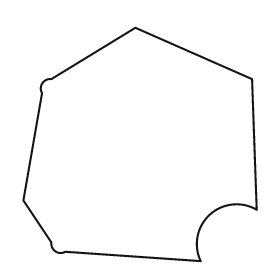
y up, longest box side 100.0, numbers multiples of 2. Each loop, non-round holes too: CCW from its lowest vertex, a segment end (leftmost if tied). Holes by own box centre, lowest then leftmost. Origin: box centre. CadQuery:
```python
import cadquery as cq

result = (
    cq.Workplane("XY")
    .moveTo(26.0, -50.0)
    .threePointArc((30.0, -30.0), (50.0, -28.0))
    .lineTo(48.0, 28.0)
    .lineTo(-2.0, 50.0)
    .lineTo(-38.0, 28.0)
    .threePointArc((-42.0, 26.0), (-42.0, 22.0))
    .lineTo(-50.0, -24.0)
    .lineTo(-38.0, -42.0)
    .threePointArc((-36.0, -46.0), (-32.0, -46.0))
    .close()
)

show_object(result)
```